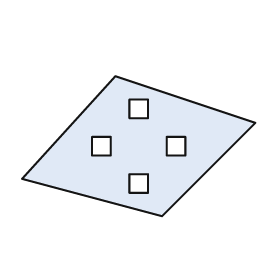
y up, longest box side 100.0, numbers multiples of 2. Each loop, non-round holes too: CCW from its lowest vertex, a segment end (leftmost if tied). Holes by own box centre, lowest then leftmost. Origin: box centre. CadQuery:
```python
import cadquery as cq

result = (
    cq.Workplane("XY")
    .moveTo(10.0, -30.0)
    .lineTo(50.0, 10.0)
    .lineTo(-10.0, 30.0)
    .lineTo(-50.0, -14.0)
    .close()
    .moveTo(-4.0, -20.0)
    .lineTo(4.0, -20.0)
    .lineTo(4.0, -12.0)
    .lineTo(-4.0, -12.0)
    .close()
    .moveTo(-20.0, -4.0)
    .lineTo(-12.0, -4.0)
    .lineTo(-12.0, 4.0)
    .lineTo(-20.0, 4.0)
    .close()
    .moveTo(12.0, -4.0)
    .lineTo(20.0, -4.0)
    .lineTo(20.0, 4.0)
    .lineTo(12.0, 4.0)
    .close()
    .moveTo(-4.0, 12.0)
    .lineTo(4.0, 12.0)
    .lineTo(4.0, 20.0)
    .lineTo(-4.0, 20.0)
    .close()
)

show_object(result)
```